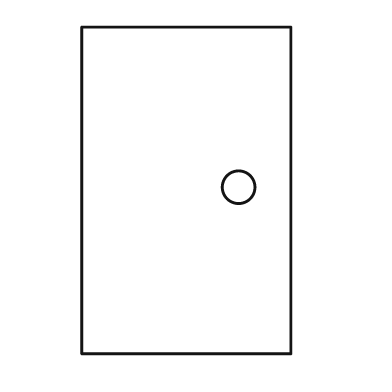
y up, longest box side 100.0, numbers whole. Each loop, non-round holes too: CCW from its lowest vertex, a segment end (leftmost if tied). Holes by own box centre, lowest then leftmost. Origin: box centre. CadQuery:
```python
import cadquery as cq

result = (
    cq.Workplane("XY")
    .moveTo(-32.0, -50.0)
    .lineTo(32.0, -50.0)
    .lineTo(32.0, 50.0)
    .lineTo(-32.0, 50.0)
    .close()
    .moveTo(16.0, 1.0)
    .circle(5.0)
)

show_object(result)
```